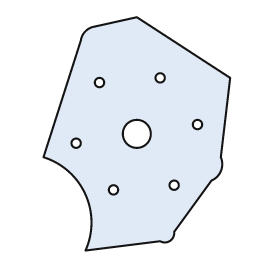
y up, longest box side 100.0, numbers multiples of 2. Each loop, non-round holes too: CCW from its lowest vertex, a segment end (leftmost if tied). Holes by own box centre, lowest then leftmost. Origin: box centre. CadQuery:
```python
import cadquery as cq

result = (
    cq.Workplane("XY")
    .moveTo(-22.0, -50.0)
    .lineTo(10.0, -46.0)
    .threePointArc((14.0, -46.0), (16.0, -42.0))
    .lineTo(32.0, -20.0)
    .threePointArc((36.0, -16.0), (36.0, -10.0))
    .lineTo(40.0, 24.0)
    .lineTo(0.0, 50.0)
    .lineTo(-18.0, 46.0)
    .threePointArc((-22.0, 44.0), (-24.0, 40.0))
    .lineTo(-40.0, -10.0)
    .threePointArc((-22.0, -26.0), (-22.0, -50.0))
    .close()
    .moveTo(-10.0, -24.0)
    .circle(2.0)
    .moveTo(16.0, -22.0)
    .circle(2.0)
    .moveTo(-26.0, -4.0)
    .circle(2.0)
    .moveTo(0.0, 0.0)
    .circle(6.0)
    .moveTo(26.0, 4.0)
    .circle(2.0)
    .moveTo(-16.0, 22.0)
    .circle(2.0)
    .moveTo(10.0, 24.0)
    .circle(2.0)
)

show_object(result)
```